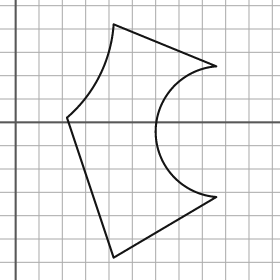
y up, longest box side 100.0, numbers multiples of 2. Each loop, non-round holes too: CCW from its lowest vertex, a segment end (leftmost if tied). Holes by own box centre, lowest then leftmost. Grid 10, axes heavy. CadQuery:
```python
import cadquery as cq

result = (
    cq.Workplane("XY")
    .moveTo(42.0, -58.0)
    .lineTo(86.0, -32.0)
    .threePointArc((60.0, -4.0), (86.0, 24.0))
    .lineTo(42.0, 42.0)
    .threePointArc((36.0, 20.0), (22.0, 2.0))
    .close()
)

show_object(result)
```